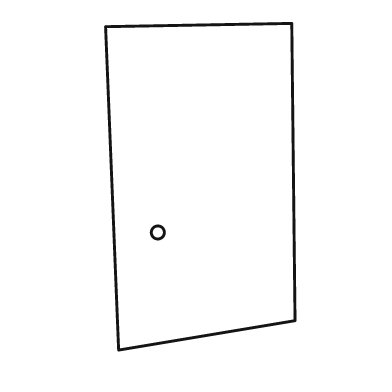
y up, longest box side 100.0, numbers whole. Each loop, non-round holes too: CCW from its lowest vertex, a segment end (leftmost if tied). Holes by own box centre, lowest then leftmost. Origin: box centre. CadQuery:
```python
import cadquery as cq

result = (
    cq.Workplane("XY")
    .moveTo(-25.0, -50.0)
    .lineTo(29.0, -41.0)
    .lineTo(28.0, 50.0)
    .lineTo(-29.0, 49.0)
    .close()
    .moveTo(-13.0, -14.0)
    .circle(2.0)
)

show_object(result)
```